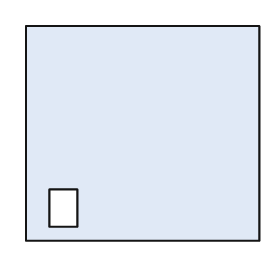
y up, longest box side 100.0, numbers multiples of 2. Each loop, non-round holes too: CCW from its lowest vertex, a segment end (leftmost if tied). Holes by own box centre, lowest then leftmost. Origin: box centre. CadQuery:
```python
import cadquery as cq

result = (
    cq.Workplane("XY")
    .moveTo(-50.0, -46.0)
    .lineTo(50.0, -46.0)
    .lineTo(50.0, 46.0)
    .lineTo(-50.0, 46.0)
    .close()
    .moveTo(-40.0, -40.0)
    .lineTo(-28.0, -40.0)
    .lineTo(-28.0, -24.0)
    .lineTo(-40.0, -24.0)
    .close()
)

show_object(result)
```